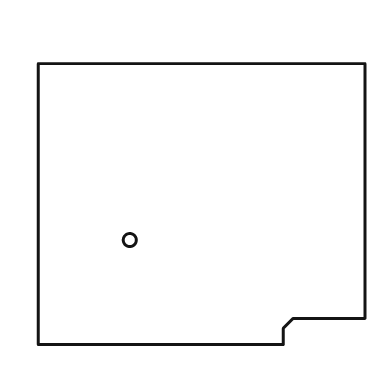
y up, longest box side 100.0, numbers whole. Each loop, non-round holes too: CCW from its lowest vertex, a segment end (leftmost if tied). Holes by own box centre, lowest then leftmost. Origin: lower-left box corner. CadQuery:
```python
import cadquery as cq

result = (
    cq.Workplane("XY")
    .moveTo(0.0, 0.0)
    .lineTo(75.0, 0.0)
    .lineTo(75.0, 5.0)
    .lineTo(78.0, 8.0)
    .lineTo(100.0, 8.0)
    .lineTo(100.0, 86.0)
    .lineTo(0.0, 86.0)
    .close()
    .moveTo(28.0, 32.0)
    .circle(2.0)
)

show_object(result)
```